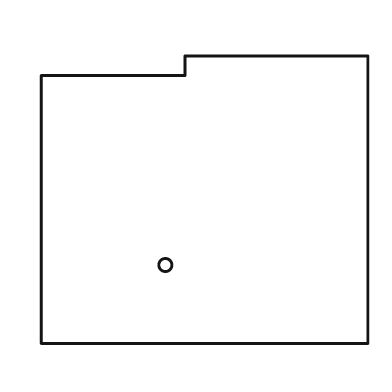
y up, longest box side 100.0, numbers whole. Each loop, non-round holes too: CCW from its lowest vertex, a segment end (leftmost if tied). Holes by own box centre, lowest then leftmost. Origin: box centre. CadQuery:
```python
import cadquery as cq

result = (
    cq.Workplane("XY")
    .moveTo(-50.0, -44.0)
    .lineTo(50.0, -44.0)
    .lineTo(50.0, 44.0)
    .lineTo(-6.0, 44.0)
    .lineTo(-6.0, 38.0)
    .lineTo(-50.0, 38.0)
    .close()
    .moveTo(-12.0, -20.0)
    .circle(2.0)
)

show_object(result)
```